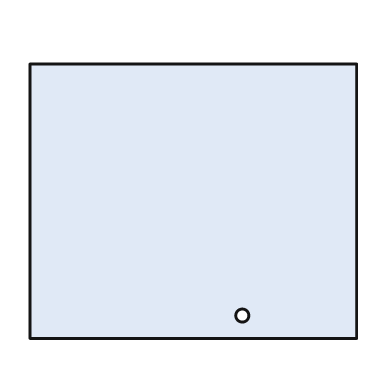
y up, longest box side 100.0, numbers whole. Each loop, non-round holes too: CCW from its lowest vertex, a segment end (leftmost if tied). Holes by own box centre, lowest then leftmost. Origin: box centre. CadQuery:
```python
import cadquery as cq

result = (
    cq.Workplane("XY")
    .moveTo(-50.0, -42.0)
    .lineTo(50.0, -42.0)
    .lineTo(50.0, 42.0)
    .lineTo(-50.0, 42.0)
    .close()
    .moveTo(15.0, -35.0)
    .circle(2.0)
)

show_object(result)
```